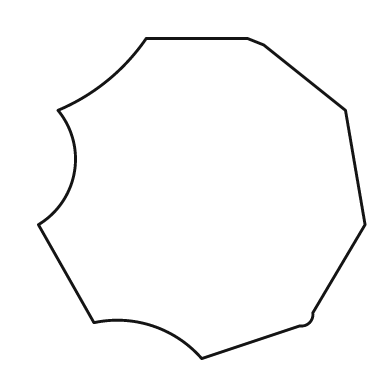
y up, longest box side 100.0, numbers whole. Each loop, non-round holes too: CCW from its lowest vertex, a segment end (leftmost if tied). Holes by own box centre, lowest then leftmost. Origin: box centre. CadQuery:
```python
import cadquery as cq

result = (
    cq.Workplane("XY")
    .moveTo(0.0, -49.0)
    .lineTo(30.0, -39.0)
    .threePointArc((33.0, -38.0), (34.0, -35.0))
    .lineTo(50.0, -8.0)
    .lineTo(44.0, 27.0)
    .lineTo(19.0, 47.0)
    .lineTo(14.0, 49.0)
    .lineTo(-17.0, 49.0)
    .threePointArc((-29.0, 36.0), (-44.0, 27.0))
    .threePointArc((-39.0, 8.0), (-50.0, -8.0))
    .lineTo(-33.0, -38.0)
    .threePointArc((-15.0, -39.0), (0.0, -49.0))
    .close()
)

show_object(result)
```